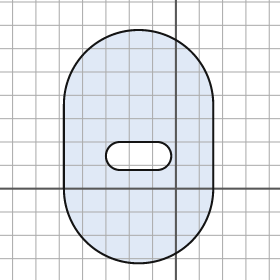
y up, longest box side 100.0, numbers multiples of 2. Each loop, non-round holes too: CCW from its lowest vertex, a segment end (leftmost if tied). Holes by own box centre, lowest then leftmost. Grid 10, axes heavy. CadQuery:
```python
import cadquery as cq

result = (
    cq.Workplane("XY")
    .moveTo(-48.0, 0.0)
    .threePointArc((-16.0, -32.0), (16.0, 0.0))
    .lineTo(16.0, 36.0)
    .threePointArc((-16.0, 68.0), (-48.0, 36.0))
    .close()
    .moveTo(-24.0, 8.0)
    .lineTo(-8.0, 8.0)
    .threePointArc((-2.0, 14.0), (-8.0, 20.0))
    .lineTo(-24.0, 20.0)
    .threePointArc((-30.0, 14.0), (-24.0, 8.0))
    .close()
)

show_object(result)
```